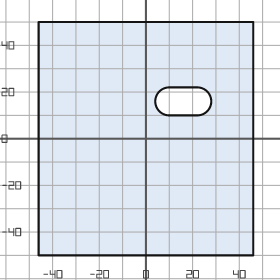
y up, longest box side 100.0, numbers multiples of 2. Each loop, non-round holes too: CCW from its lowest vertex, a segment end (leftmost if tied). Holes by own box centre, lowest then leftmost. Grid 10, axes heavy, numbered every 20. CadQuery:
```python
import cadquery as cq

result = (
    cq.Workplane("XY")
    .moveTo(-46.0, -50.0)
    .lineTo(46.0, -50.0)
    .lineTo(46.0, 50.0)
    .lineTo(-46.0, 50.0)
    .close()
    .moveTo(10.0, 10.0)
    .lineTo(22.0, 10.0)
    .threePointArc((28.0, 16.0), (22.0, 22.0))
    .lineTo(10.0, 22.0)
    .threePointArc((4.0, 16.0), (10.0, 10.0))
    .close()
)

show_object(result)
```